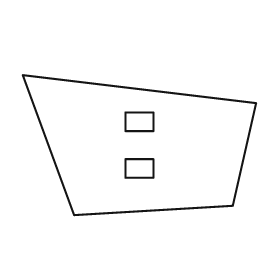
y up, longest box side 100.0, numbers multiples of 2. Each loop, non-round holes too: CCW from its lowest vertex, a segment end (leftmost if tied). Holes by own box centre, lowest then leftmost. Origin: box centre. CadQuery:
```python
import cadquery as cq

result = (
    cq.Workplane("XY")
    .moveTo(-28.0, -30.0)
    .lineTo(40.0, -26.0)
    .lineTo(50.0, 18.0)
    .lineTo(-50.0, 30.0)
    .close()
    .moveTo(-6.0, -14.0)
    .lineTo(6.0, -14.0)
    .lineTo(6.0, -6.0)
    .lineTo(-6.0, -6.0)
    .close()
    .moveTo(-6.0, 6.0)
    .lineTo(6.0, 6.0)
    .lineTo(6.0, 14.0)
    .lineTo(-6.0, 14.0)
    .close()
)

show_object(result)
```